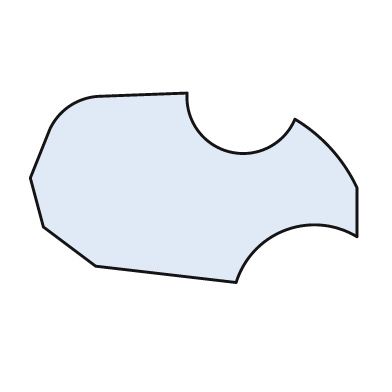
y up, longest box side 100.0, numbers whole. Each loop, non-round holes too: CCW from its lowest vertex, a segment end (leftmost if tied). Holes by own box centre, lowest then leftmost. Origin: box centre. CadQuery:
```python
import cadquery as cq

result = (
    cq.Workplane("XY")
    .moveTo(13.0, -29.0)
    .threePointArc((28.0, -13.0), (50.0, -15.0))
    .lineTo(50.0, 0.0)
    .threePointArc((42.0, 12.0), (31.0, 21.0))
    .threePointArc((11.0, 11.0), (-2.0, 29.0))
    .lineTo(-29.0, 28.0)
    .threePointArc((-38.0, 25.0), (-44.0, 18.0))
    .lineTo(-50.0, 3.0)
    .lineTo(-46.0, -12.0)
    .lineTo(-30.0, -24.0)
    .close()
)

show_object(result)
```